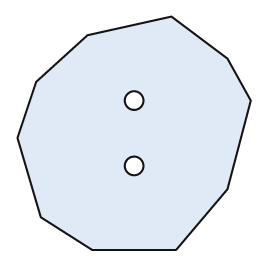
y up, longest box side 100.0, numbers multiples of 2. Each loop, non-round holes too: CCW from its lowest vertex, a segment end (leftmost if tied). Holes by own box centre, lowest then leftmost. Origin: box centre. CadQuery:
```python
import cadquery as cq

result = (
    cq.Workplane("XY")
    .moveTo(-18.0, -50.0)
    .lineTo(18.0, -50.0)
    .lineTo(40.0, -24.0)
    .lineTo(50.0, 14.0)
    .lineTo(40.0, 32.0)
    .lineTo(16.0, 50.0)
    .lineTo(-20.0, 42.0)
    .lineTo(-42.0, 22.0)
    .lineTo(-50.0, -2.0)
    .lineTo(-40.0, -36.0)
    .close()
    .moveTo(0.0, -14.0)
    .circle(4.0)
    .moveTo(0.0, 14.0)
    .circle(4.0)
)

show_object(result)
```